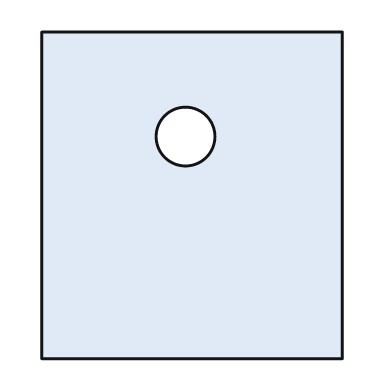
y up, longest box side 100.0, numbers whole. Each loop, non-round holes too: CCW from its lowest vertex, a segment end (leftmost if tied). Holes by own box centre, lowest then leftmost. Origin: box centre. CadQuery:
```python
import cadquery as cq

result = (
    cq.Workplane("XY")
    .moveTo(-46.0, -50.0)
    .lineTo(46.0, -50.0)
    .lineTo(46.0, 50.0)
    .lineTo(-46.0, 50.0)
    .close()
    .moveTo(-2.0, 18.0)
    .circle(9.0)
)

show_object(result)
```